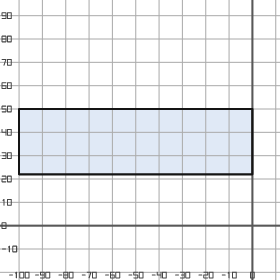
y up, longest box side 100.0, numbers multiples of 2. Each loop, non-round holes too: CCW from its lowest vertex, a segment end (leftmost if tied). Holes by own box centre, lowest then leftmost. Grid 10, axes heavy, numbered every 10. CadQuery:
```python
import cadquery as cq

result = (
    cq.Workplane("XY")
    .moveTo(-100.0, 22.0)
    .lineTo(0.0, 22.0)
    .lineTo(0.0, 50.0)
    .lineTo(-100.0, 50.0)
    .close()
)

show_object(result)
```